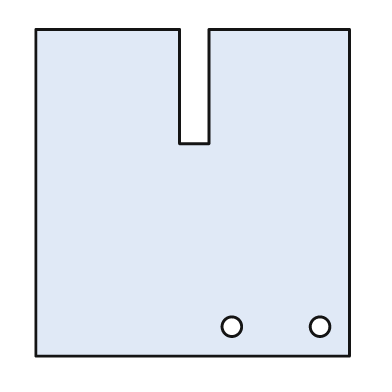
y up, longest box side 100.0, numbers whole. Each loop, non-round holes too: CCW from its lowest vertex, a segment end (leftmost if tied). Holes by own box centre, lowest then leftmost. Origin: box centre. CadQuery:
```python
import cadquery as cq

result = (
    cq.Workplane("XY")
    .moveTo(-48.0, -50.0)
    .lineTo(48.0, -50.0)
    .lineTo(48.0, 50.0)
    .lineTo(5.0, 50.0)
    .lineTo(5.0, 15.0)
    .lineTo(-4.0, 15.0)
    .lineTo(-4.0, 50.0)
    .lineTo(-48.0, 50.0)
    .close()
    .moveTo(12.0, -41.0)
    .circle(3.0)
    .moveTo(39.0, -41.0)
    .circle(3.0)
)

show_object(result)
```